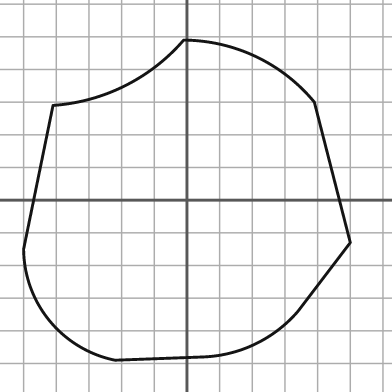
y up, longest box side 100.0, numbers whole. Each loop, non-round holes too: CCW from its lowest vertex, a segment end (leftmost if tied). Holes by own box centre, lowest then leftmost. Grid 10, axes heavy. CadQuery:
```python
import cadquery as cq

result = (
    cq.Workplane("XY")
    .moveTo(-22.0, -49.0)
    .lineTo(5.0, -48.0)
    .threePointArc((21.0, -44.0), (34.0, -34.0))
    .lineTo(50.0, -13.0)
    .lineTo(39.0, 30.0)
    .threePointArc((21.0, 44.0), (-1.0, 49.0))
    .threePointArc((-19.0, 35.0), (-41.0, 29.0))
    .lineTo(-50.0, -15.0)
    .threePointArc((-42.0, -37.0), (-22.0, -49.0))
    .close()
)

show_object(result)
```